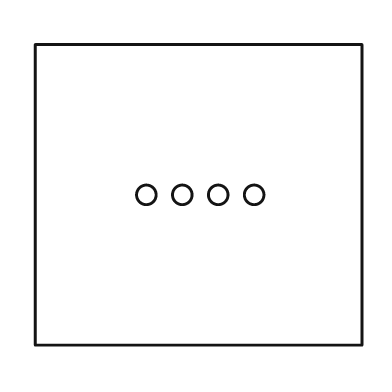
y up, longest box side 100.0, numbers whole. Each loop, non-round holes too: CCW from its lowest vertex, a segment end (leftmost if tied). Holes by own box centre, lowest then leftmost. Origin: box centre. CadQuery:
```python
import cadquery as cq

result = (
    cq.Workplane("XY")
    .moveTo(-50.0, -46.0)
    .lineTo(50.0, -46.0)
    .lineTo(50.0, 46.0)
    .lineTo(-50.0, 46.0)
    .close()
    .moveTo(-16.0, 0.0)
    .circle(3.0)
    .moveTo(-5.0, 0.0)
    .circle(3.0)
    .moveTo(6.0, 0.0)
    .circle(3.0)
    .moveTo(17.0, 0.0)
    .circle(3.0)
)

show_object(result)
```